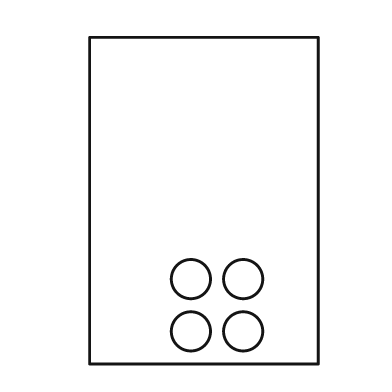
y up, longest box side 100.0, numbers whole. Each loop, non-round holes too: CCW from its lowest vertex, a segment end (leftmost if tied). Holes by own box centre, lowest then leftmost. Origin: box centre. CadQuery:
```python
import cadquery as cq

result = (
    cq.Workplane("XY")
    .moveTo(-35.0, -50.0)
    .lineTo(35.0, -50.0)
    .lineTo(35.0, 50.0)
    .lineTo(-35.0, 50.0)
    .close()
    .moveTo(-4.0, -40.0)
    .circle(6.0)
    .moveTo(12.0, -40.0)
    .circle(6.0)
    .moveTo(-4.0, -24.0)
    .circle(6.0)
    .moveTo(12.0, -24.0)
    .circle(6.0)
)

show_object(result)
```